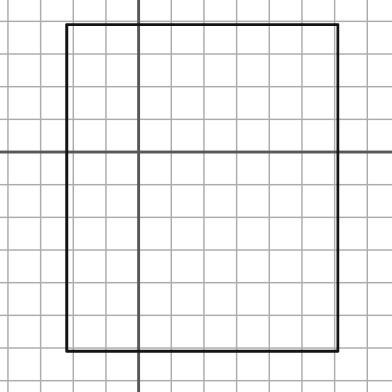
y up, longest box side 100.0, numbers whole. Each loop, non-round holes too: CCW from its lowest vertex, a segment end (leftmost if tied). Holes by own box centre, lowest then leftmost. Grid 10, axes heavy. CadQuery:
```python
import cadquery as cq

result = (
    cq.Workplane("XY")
    .moveTo(-22.0, -61.0)
    .lineTo(61.0, -61.0)
    .lineTo(61.0, 39.0)
    .lineTo(-22.0, 39.0)
    .close()
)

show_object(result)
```